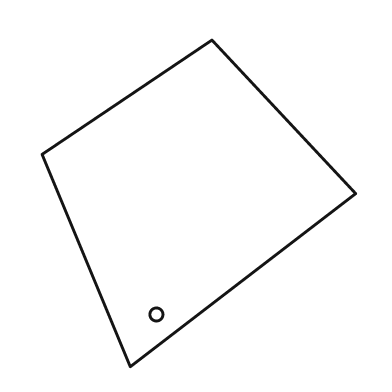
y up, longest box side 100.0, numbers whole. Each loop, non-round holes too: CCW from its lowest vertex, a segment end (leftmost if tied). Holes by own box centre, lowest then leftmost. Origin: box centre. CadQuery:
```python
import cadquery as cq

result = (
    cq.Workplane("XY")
    .moveTo(-21.0, -50.0)
    .lineTo(48.0, 3.0)
    .lineTo(4.0, 50.0)
    .lineTo(-48.0, 15.0)
    .close()
    .moveTo(-13.0, -34.0)
    .circle(2.0)
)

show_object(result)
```